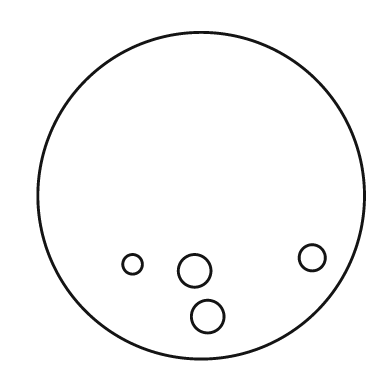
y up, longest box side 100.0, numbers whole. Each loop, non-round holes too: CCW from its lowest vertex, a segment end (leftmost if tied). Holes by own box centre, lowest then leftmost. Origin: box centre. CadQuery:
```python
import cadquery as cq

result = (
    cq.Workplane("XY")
    .moveTo(0.0, 0.0)
    .circle(50.0)
    .moveTo(2.0, -37.0)
    .circle(5.0)
    .moveTo(-2.0, -23.0)
    .circle(5.0)
    .moveTo(-21.0, -21.0)
    .circle(3.0)
    .moveTo(34.0, -19.0)
    .circle(4.0)
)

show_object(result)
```